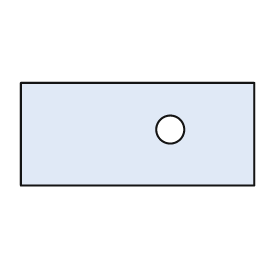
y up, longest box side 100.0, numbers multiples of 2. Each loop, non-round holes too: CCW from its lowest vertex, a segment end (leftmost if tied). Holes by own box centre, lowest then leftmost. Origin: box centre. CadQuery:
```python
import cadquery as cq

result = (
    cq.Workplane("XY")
    .moveTo(-50.0, -22.0)
    .lineTo(50.0, -22.0)
    .lineTo(50.0, 22.0)
    .lineTo(-50.0, 22.0)
    .close()
    .moveTo(14.0, 2.0)
    .circle(6.0)
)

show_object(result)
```